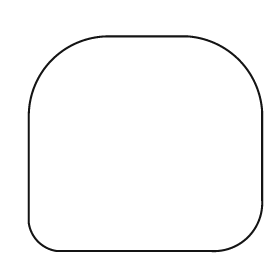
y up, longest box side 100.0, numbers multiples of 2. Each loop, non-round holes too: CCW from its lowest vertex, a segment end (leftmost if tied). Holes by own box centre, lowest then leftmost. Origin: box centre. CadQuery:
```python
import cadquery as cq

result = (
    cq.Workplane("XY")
    .moveTo(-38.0, -46.0)
    .lineTo(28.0, -46.0)
    .threePointArc((44.0, -40.0), (50.0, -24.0))
    .lineTo(50.0, 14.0)
    .threePointArc((40.0, 36.0), (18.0, 46.0))
    .lineTo(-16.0, 46.0)
    .threePointArc((-40.0, 36.0), (-50.0, 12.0))
    .lineTo(-50.0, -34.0)
    .threePointArc((-46.0, -42.0), (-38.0, -46.0))
    .close()
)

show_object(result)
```